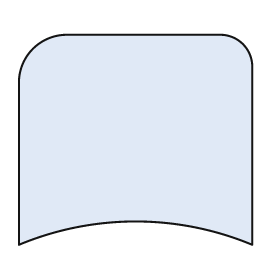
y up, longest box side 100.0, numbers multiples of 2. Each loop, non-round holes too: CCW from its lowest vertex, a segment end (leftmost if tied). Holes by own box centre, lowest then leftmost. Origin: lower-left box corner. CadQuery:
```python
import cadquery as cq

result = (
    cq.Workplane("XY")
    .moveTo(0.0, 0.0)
    .threePointArc((50.0, 10.0), (100.0, 0.0))
    .lineTo(100.0, 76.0)
    .threePointArc((96.0, 86.0), (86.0, 90.0))
    .lineTo(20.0, 90.0)
    .threePointArc((6.0, 84.0), (0.0, 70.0))
    .close()
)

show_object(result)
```